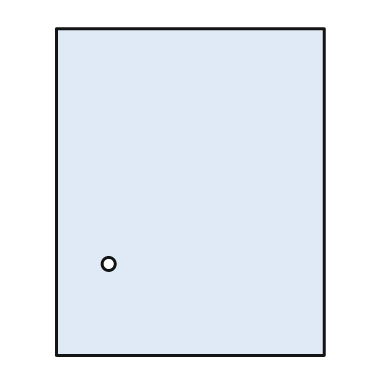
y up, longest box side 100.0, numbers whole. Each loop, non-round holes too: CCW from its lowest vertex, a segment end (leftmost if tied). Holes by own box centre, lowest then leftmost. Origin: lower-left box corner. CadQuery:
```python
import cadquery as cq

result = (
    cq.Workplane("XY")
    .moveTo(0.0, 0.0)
    .lineTo(82.0, 0.0)
    .lineTo(82.0, 100.0)
    .lineTo(0.0, 100.0)
    .close()
    .moveTo(16.0, 28.0)
    .circle(2.0)
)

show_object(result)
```